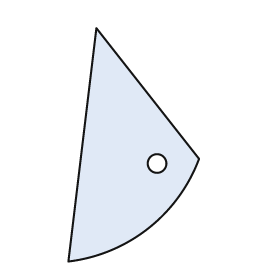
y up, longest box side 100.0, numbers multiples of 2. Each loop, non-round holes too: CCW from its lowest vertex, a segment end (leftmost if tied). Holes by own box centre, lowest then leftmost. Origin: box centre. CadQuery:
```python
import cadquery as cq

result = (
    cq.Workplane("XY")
    .moveTo(-28.0, -50.0)
    .threePointArc((6.0, -36.0), (28.0, -6.0))
    .lineTo(-16.0, 50.0)
    .close()
    .moveTo(10.0, -8.0)
    .circle(4.0)
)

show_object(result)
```